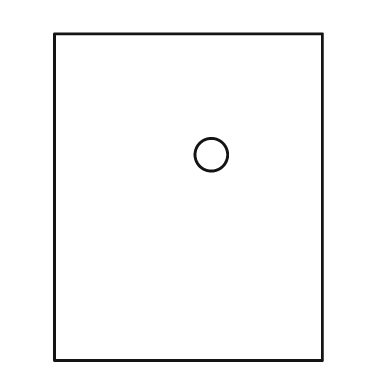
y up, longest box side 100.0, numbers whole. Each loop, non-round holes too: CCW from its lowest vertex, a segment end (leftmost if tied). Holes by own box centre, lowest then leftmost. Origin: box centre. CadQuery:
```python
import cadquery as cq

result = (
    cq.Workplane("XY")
    .moveTo(-41.0, -50.0)
    .lineTo(41.0, -50.0)
    .lineTo(41.0, 50.0)
    .lineTo(-41.0, 50.0)
    .close()
    .moveTo(7.0, 13.0)
    .circle(5.0)
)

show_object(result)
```